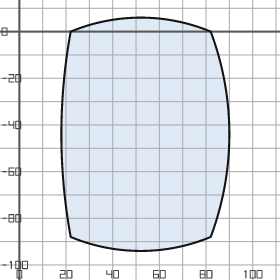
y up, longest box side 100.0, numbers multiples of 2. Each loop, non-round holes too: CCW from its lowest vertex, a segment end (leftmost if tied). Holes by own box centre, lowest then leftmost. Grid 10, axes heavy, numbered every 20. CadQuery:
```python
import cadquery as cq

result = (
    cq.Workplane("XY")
    .moveTo(22.0, -88.0)
    .threePointArc((52.0, -94.0), (82.0, -88.0))
    .threePointArc((90.0, -44.0), (82.0, 0.0))
    .threePointArc((52.0, 6.0), (22.0, 0.0))
    .threePointArc((18.0, -44.0), (22.0, -88.0))
    .close()
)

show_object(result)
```